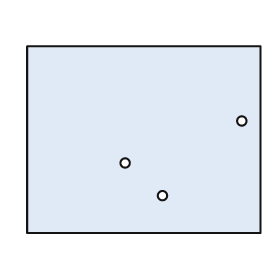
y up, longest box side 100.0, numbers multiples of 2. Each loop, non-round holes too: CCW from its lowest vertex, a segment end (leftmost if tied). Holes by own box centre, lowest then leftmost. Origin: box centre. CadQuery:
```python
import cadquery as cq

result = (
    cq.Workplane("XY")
    .moveTo(-50.0, -40.0)
    .lineTo(50.0, -40.0)
    .lineTo(50.0, 40.0)
    .lineTo(-50.0, 40.0)
    .close()
    .moveTo(8.0, -24.0)
    .circle(2.0)
    .moveTo(-8.0, -10.0)
    .circle(2.0)
    .moveTo(42.0, 8.0)
    .circle(2.0)
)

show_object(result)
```